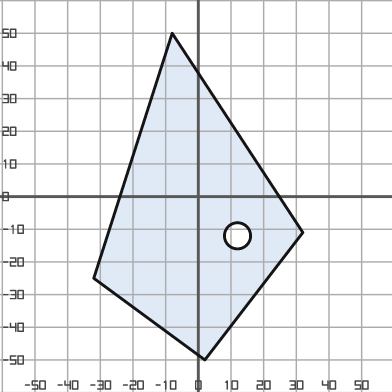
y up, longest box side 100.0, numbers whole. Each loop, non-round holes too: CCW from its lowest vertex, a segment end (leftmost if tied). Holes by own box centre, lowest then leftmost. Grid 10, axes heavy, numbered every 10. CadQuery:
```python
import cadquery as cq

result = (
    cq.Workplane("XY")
    .moveTo(2.0, -50.0)
    .lineTo(32.0, -11.0)
    .lineTo(-8.0, 50.0)
    .lineTo(-32.0, -25.0)
    .close()
    .moveTo(12.0, -12.0)
    .circle(4.0)
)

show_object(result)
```